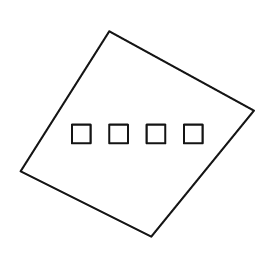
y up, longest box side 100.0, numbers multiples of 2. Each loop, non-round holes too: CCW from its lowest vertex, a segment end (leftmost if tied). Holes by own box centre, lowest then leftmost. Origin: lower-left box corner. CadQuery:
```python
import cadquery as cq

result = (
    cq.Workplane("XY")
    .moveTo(56.0, 0.0)
    .lineTo(100.0, 54.0)
    .lineTo(38.0, 88.0)
    .lineTo(0.0, 28.0)
    .close()
    .moveTo(22.0, 40.0)
    .lineTo(30.0, 40.0)
    .lineTo(30.0, 48.0)
    .lineTo(22.0, 48.0)
    .close()
    .moveTo(38.0, 40.0)
    .lineTo(46.0, 40.0)
    .lineTo(46.0, 48.0)
    .lineTo(38.0, 48.0)
    .close()
    .moveTo(54.0, 40.0)
    .lineTo(62.0, 40.0)
    .lineTo(62.0, 48.0)
    .lineTo(54.0, 48.0)
    .close()
    .moveTo(70.0, 40.0)
    .lineTo(78.0, 40.0)
    .lineTo(78.0, 48.0)
    .lineTo(70.0, 48.0)
    .close()
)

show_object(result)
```